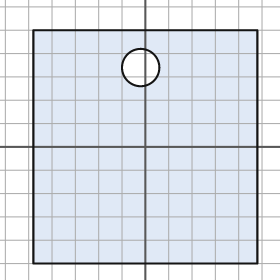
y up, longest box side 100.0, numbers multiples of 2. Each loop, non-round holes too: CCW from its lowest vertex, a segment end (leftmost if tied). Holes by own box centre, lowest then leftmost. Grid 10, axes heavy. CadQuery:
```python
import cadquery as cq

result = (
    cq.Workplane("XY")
    .moveTo(-48.0, -50.0)
    .lineTo(48.0, -50.0)
    .lineTo(48.0, 50.0)
    .lineTo(-48.0, 50.0)
    .close()
    .moveTo(-2.0, 34.0)
    .circle(8.0)
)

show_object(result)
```